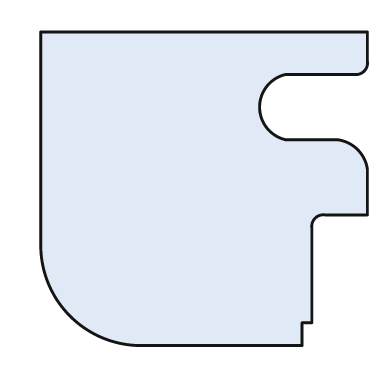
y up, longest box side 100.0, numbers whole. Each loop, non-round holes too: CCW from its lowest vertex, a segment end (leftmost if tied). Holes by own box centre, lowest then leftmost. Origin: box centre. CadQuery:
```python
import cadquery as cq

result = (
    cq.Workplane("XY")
    .moveTo(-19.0, -48.0)
    .lineTo(30.0, -48.0)
    .lineTo(30.0, -41.0)
    .lineTo(33.0, -41.0)
    .lineTo(33.0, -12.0)
    .threePointArc((34.0, -9.0), (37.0, -8.0))
    .lineTo(50.0, -8.0)
    .lineTo(50.0, 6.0)
    .threePointArc((47.0, 12.0), (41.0, 15.0))
    .lineTo(25.0, 15.0)
    .threePointArc((17.0, 25.0), (25.0, 35.0))
    .lineTo(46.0, 35.0)
    .threePointArc((49.0, 36.0), (50.0, 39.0))
    .lineTo(50.0, 48.0)
    .lineTo(-50.0, 48.0)
    .lineTo(-50.0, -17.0)
    .threePointArc((-41.0, -39.0), (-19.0, -48.0))
    .close()
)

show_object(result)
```